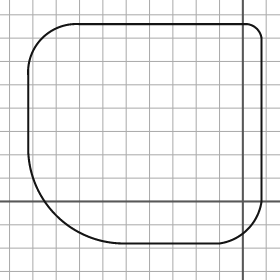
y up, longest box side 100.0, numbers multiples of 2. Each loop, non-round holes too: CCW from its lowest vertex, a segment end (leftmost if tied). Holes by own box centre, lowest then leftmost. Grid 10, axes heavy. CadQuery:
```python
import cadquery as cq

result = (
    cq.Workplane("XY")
    .moveTo(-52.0, -18.0)
    .lineTo(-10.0, -18.0)
    .threePointArc((2.0, -12.0), (8.0, 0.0))
    .lineTo(8.0, 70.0)
    .threePointArc((6.0, 74.0), (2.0, 76.0))
    .lineTo(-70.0, 76.0)
    .threePointArc((-86.0, 70.0), (-92.0, 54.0))
    .lineTo(-92.0, 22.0)
    .threePointArc((-80.0, -6.0), (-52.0, -18.0))
    .close()
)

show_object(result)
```